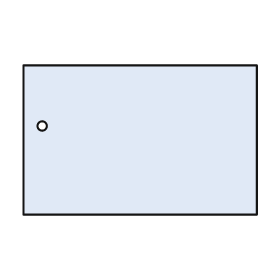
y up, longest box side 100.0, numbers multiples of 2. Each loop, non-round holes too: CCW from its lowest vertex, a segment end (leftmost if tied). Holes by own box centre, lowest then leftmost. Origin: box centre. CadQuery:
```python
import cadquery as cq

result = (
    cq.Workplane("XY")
    .moveTo(-50.0, -32.0)
    .lineTo(50.0, -32.0)
    .lineTo(50.0, 32.0)
    .lineTo(-50.0, 32.0)
    .close()
    .moveTo(-42.0, 6.0)
    .circle(2.0)
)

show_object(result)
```